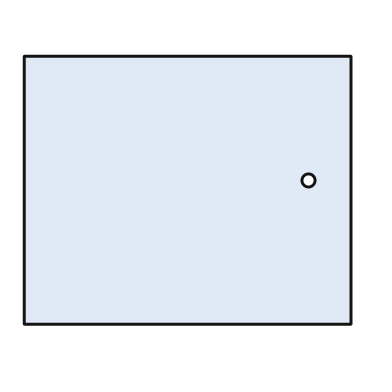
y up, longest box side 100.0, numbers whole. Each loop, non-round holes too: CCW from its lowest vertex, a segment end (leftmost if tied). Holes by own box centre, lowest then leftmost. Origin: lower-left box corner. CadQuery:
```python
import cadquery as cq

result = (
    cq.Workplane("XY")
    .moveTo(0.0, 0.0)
    .lineTo(100.0, 0.0)
    .lineTo(100.0, 82.0)
    .lineTo(0.0, 82.0)
    .close()
    .moveTo(87.0, 44.0)
    .circle(2.0)
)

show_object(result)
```